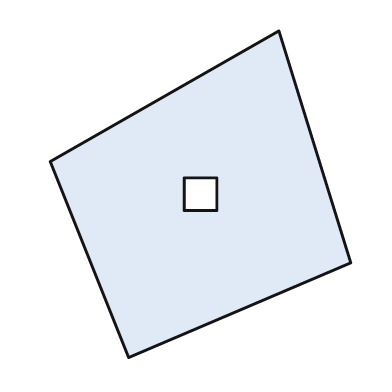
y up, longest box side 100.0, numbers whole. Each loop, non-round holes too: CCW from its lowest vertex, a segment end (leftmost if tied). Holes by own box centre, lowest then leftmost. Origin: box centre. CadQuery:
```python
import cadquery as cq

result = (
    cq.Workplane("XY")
    .moveTo(-22.0, -50.0)
    .lineTo(46.0, -21.0)
    .lineTo(24.0, 50.0)
    .lineTo(-46.0, 10.0)
    .close()
    .moveTo(-5.0, -5.0)
    .lineTo(5.0, -5.0)
    .lineTo(5.0, 5.0)
    .lineTo(-5.0, 5.0)
    .close()
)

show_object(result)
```